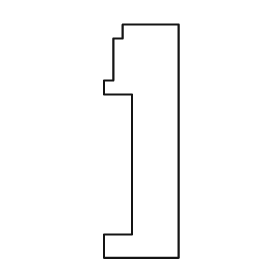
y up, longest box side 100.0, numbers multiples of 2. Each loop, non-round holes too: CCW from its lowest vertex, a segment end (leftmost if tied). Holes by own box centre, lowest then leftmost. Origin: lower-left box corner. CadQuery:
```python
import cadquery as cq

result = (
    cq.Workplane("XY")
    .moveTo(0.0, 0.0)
    .lineTo(32.0, 0.0)
    .lineTo(32.0, 100.0)
    .lineTo(8.0, 100.0)
    .lineTo(8.0, 94.0)
    .lineTo(4.0, 94.0)
    .lineTo(4.0, 76.0)
    .lineTo(0.0, 76.0)
    .lineTo(0.0, 70.0)
    .lineTo(12.0, 70.0)
    .lineTo(12.0, 10.0)
    .lineTo(0.0, 10.0)
    .close()
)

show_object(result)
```